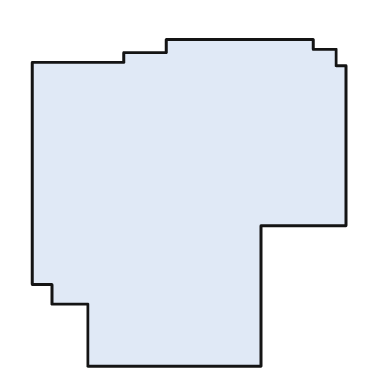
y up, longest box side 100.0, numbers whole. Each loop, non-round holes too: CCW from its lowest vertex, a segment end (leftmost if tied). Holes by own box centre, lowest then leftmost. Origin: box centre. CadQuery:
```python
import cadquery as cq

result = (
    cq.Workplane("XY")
    .moveTo(-31.0, -50.0)
    .lineTo(22.0, -50.0)
    .lineTo(22.0, -7.0)
    .lineTo(48.0, -7.0)
    .lineTo(48.0, 42.0)
    .lineTo(45.0, 42.0)
    .lineTo(45.0, 47.0)
    .lineTo(38.0, 47.0)
    .lineTo(38.0, 50.0)
    .lineTo(-7.0, 50.0)
    .lineTo(-7.0, 46.0)
    .lineTo(-20.0, 46.0)
    .lineTo(-20.0, 43.0)
    .lineTo(-48.0, 43.0)
    .lineTo(-48.0, -25.0)
    .lineTo(-42.0, -25.0)
    .lineTo(-42.0, -31.0)
    .lineTo(-31.0, -31.0)
    .close()
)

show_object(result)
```